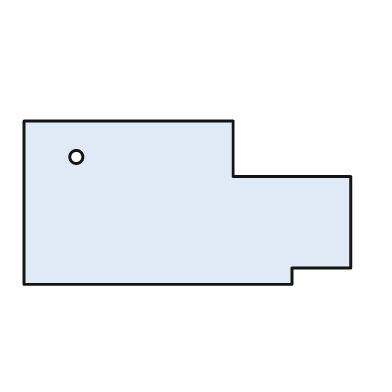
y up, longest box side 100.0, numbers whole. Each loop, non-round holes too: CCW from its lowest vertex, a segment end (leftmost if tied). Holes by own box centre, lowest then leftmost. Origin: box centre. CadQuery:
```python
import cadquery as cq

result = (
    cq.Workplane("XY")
    .moveTo(-50.0, -25.0)
    .lineTo(32.0, -25.0)
    .lineTo(32.0, -20.0)
    .lineTo(50.0, -20.0)
    .lineTo(50.0, 8.0)
    .lineTo(14.0, 8.0)
    .lineTo(14.0, 25.0)
    .lineTo(-50.0, 25.0)
    .close()
    .moveTo(-34.0, 14.0)
    .circle(2.0)
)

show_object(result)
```